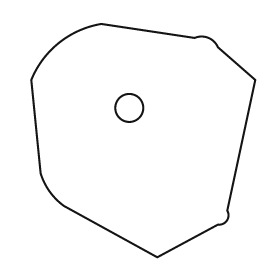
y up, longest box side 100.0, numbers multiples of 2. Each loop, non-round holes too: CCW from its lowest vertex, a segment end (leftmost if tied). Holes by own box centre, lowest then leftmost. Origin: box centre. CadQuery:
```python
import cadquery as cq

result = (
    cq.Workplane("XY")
    .moveTo(6.0, -50.0)
    .lineTo(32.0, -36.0)
    .threePointArc((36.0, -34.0), (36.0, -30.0))
    .lineTo(48.0, 26.0)
    .lineTo(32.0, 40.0)
    .threePointArc((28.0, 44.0), (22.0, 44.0))
    .lineTo(-18.0, 50.0)
    .threePointArc((-36.0, 42.0), (-48.0, 26.0))
    .lineTo(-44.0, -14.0)
    .threePointArc((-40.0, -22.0), (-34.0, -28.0))
    .close()
    .moveTo(-6.0, 14.0)
    .circle(6.0)
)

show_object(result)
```